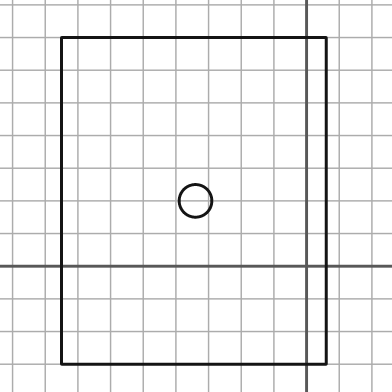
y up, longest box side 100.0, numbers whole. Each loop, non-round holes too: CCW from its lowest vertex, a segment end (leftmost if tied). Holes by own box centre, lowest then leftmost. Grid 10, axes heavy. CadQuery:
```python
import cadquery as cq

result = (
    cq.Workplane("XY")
    .moveTo(-75.0, -30.0)
    .lineTo(6.0, -30.0)
    .lineTo(6.0, 70.0)
    .lineTo(-75.0, 70.0)
    .close()
    .moveTo(-34.0, 20.0)
    .circle(5.0)
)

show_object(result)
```